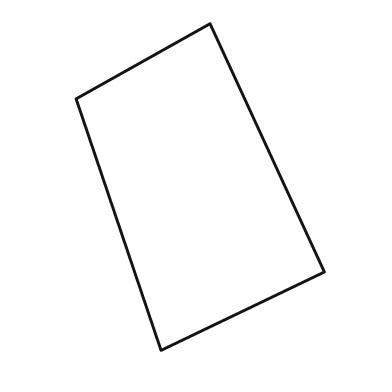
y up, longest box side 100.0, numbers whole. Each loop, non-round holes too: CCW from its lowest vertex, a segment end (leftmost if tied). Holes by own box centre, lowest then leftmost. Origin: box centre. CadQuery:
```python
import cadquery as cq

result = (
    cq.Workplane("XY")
    .moveTo(-12.0, -50.0)
    .lineTo(38.0, -26.0)
    .lineTo(3.0, 50.0)
    .lineTo(-38.0, 27.0)
    .close()
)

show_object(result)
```